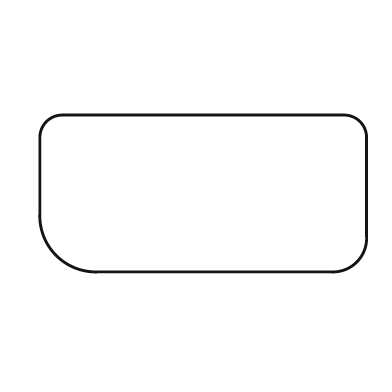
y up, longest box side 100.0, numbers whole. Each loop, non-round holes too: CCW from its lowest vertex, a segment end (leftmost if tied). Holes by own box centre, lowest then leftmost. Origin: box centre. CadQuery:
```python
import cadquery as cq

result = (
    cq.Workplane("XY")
    .moveTo(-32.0, -24.0)
    .lineTo(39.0, -24.0)
    .threePointArc((47.0, -21.0), (50.0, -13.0))
    .lineTo(50.0, 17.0)
    .threePointArc((48.0, 22.0), (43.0, 24.0))
    .lineTo(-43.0, 24.0)
    .threePointArc((-48.0, 22.0), (-50.0, 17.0))
    .lineTo(-50.0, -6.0)
    .threePointArc((-45.0, -19.0), (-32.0, -24.0))
    .close()
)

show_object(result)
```